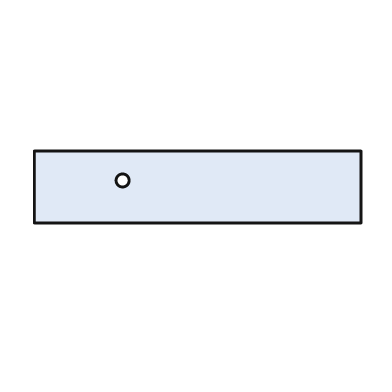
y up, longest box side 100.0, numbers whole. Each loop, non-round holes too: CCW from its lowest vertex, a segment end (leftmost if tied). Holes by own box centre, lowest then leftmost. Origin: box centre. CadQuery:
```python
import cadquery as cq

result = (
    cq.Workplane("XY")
    .moveTo(-50.0, -11.0)
    .lineTo(50.0, -11.0)
    .lineTo(50.0, 11.0)
    .lineTo(-50.0, 11.0)
    .close()
    .moveTo(-23.0, 2.0)
    .circle(2.0)
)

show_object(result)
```